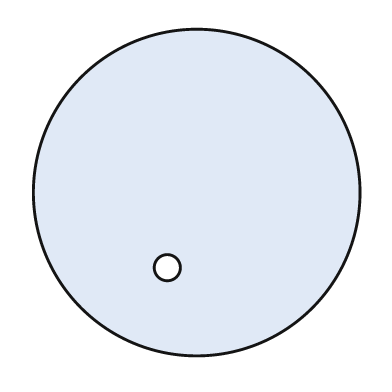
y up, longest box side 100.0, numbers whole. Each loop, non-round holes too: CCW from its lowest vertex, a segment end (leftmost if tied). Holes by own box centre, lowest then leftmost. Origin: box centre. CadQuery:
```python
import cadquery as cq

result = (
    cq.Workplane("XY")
    .moveTo(0.0, 0.0)
    .circle(50.0)
    .moveTo(-9.0, -23.0)
    .circle(4.0)
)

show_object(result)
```